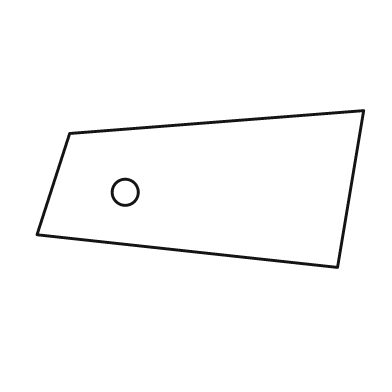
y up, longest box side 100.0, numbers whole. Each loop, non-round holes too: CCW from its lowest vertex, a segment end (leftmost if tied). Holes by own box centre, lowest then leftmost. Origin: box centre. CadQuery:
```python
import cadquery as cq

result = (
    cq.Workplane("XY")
    .moveTo(42.0, -24.0)
    .lineTo(50.0, 24.0)
    .lineTo(-40.0, 17.0)
    .lineTo(-50.0, -14.0)
    .close()
    .moveTo(-23.0, -1.0)
    .circle(4.0)
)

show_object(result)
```